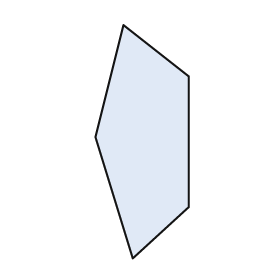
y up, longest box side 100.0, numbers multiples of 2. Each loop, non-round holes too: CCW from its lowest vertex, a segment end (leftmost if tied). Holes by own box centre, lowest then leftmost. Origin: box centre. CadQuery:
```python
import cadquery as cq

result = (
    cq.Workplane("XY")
    .moveTo(-4.0, -50.0)
    .lineTo(20.0, -28.0)
    .lineTo(20.0, 28.0)
    .lineTo(-8.0, 50.0)
    .lineTo(-20.0, 2.0)
    .close()
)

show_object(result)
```